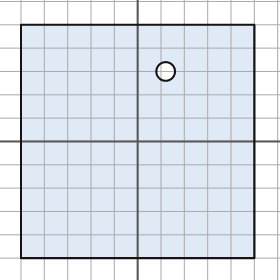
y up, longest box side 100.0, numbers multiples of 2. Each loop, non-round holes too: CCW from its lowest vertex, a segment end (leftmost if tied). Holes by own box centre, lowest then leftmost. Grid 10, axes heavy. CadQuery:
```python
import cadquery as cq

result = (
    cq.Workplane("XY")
    .moveTo(-50.0, -50.0)
    .lineTo(50.0, -50.0)
    .lineTo(50.0, 50.0)
    .lineTo(-50.0, 50.0)
    .close()
    .moveTo(12.0, 30.0)
    .circle(4.0)
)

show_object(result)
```